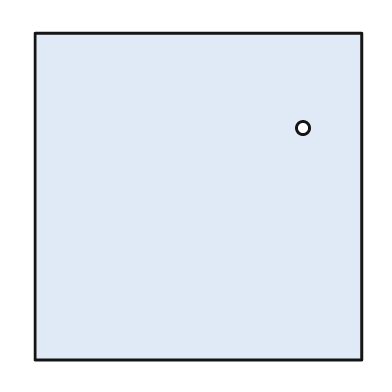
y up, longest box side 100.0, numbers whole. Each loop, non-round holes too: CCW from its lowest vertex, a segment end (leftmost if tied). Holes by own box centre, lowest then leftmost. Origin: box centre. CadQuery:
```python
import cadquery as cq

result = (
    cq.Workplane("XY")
    .moveTo(-50.0, -50.0)
    .lineTo(50.0, -50.0)
    .lineTo(50.0, 50.0)
    .lineTo(-50.0, 50.0)
    .close()
    .moveTo(32.0, 21.0)
    .circle(2.0)
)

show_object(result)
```